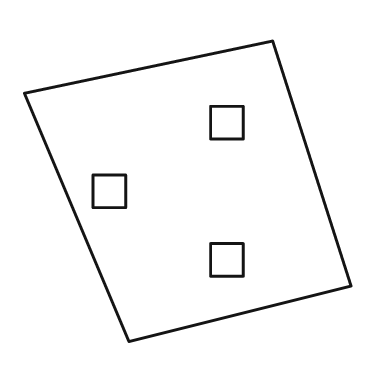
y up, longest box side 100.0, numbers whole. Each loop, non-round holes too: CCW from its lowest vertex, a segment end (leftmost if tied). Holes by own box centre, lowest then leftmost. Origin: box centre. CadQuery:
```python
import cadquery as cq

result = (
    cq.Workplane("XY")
    .moveTo(-18.0, -46.0)
    .lineTo(50.0, -29.0)
    .lineTo(26.0, 46.0)
    .lineTo(-50.0, 30.0)
    .close()
    .moveTo(7.0, -26.0)
    .lineTo(17.0, -26.0)
    .lineTo(17.0, -16.0)
    .lineTo(7.0, -16.0)
    .close()
    .moveTo(-29.0, -5.0)
    .lineTo(-19.0, -5.0)
    .lineTo(-19.0, 5.0)
    .lineTo(-29.0, 5.0)
    .close()
    .moveTo(7.0, 16.0)
    .lineTo(17.0, 16.0)
    .lineTo(17.0, 26.0)
    .lineTo(7.0, 26.0)
    .close()
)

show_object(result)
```